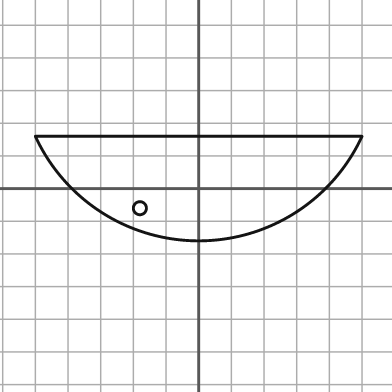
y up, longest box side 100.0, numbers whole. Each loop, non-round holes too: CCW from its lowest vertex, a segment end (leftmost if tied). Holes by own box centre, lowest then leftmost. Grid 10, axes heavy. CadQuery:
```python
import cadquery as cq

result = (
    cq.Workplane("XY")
    .moveTo(-50.0, 16.0)
    .threePointArc((0.0, -16.0), (50.0, 16.0))
    .close()
    .moveTo(-18.0, -6.0)
    .circle(2.0)
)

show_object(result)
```